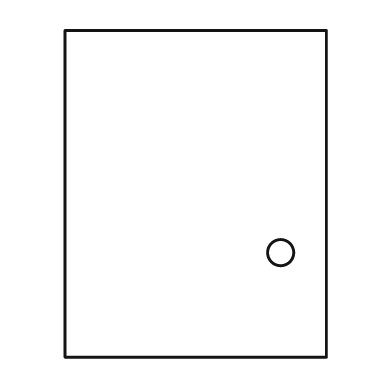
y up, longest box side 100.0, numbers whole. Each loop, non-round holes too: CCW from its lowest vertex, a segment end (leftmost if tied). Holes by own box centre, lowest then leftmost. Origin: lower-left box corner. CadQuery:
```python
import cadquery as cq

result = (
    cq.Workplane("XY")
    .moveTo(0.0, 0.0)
    .lineTo(80.0, 0.0)
    .lineTo(80.0, 100.0)
    .lineTo(0.0, 100.0)
    .close()
    .moveTo(66.0, 32.0)
    .circle(4.0)
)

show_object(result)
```